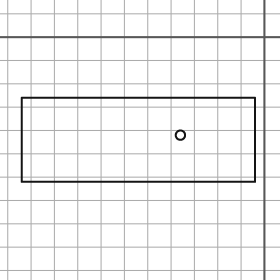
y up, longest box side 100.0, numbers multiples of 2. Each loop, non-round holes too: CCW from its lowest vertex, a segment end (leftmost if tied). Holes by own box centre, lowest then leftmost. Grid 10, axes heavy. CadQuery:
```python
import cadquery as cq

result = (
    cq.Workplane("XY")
    .moveTo(-104.0, -62.0)
    .lineTo(-4.0, -62.0)
    .lineTo(-4.0, -26.0)
    .lineTo(-104.0, -26.0)
    .close()
    .moveTo(-36.0, -42.0)
    .circle(2.0)
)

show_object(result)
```